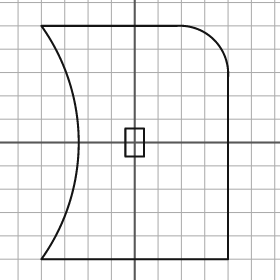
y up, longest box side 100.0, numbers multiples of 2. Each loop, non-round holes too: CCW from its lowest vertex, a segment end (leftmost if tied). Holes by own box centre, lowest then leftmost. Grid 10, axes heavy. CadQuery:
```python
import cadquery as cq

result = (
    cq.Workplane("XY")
    .moveTo(-40.0, -50.0)
    .lineTo(40.0, -50.0)
    .lineTo(40.0, 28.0)
    .threePointArc((34.0, 44.0), (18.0, 50.0))
    .lineTo(-40.0, 50.0)
    .threePointArc((-24.0, 0.0), (-40.0, -50.0))
    .close()
    .moveTo(-4.0, -6.0)
    .lineTo(4.0, -6.0)
    .lineTo(4.0, 6.0)
    .lineTo(-4.0, 6.0)
    .close()
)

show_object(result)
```